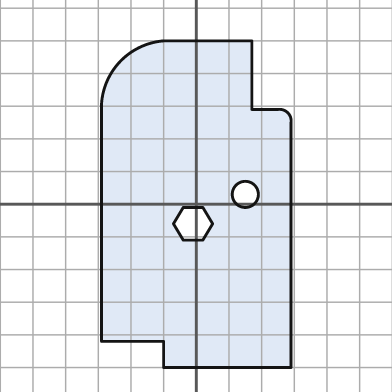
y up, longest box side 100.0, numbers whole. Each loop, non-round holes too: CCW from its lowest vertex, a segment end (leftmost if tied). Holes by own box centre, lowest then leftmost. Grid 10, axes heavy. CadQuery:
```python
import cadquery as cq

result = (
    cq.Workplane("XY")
    .moveTo(-10.0, -50.0)
    .lineTo(29.0, -50.0)
    .lineTo(29.0, 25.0)
    .threePointArc((28.0, 28.0), (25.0, 29.0))
    .lineTo(17.0, 29.0)
    .lineTo(17.0, 50.0)
    .lineTo(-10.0, 50.0)
    .threePointArc((-23.0, 44.0), (-29.0, 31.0))
    .lineTo(-29.0, -42.0)
    .lineTo(-10.0, -42.0)
    .close()
    .moveTo(-4.0, -11.0)
    .lineTo(2.0, -11.0)
    .lineTo(5.0, -6.0)
    .lineTo(2.0, -1.0)
    .lineTo(-4.0, -1.0)
    .lineTo(-7.0, -6.0)
    .close()
    .moveTo(15.0, 3.0)
    .circle(4.0)
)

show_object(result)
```